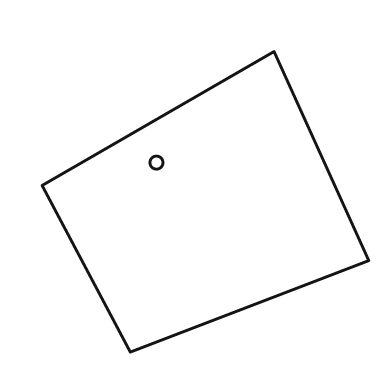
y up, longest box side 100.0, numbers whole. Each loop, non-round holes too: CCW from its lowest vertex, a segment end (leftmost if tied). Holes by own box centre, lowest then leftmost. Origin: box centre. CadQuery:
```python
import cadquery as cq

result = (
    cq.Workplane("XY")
    .moveTo(-23.0, -46.0)
    .lineTo(50.0, -18.0)
    .lineTo(21.0, 46.0)
    .lineTo(-50.0, 5.0)
    .close()
    .moveTo(-15.0, 12.0)
    .circle(2.0)
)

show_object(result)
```